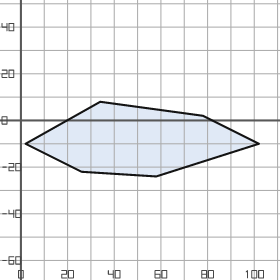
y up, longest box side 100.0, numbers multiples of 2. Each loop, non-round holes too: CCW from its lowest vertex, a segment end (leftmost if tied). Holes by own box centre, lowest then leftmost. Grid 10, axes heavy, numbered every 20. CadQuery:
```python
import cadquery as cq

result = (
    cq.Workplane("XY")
    .moveTo(58.0, -24.0)
    .lineTo(102.0, -10.0)
    .lineTo(78.0, 2.0)
    .lineTo(34.0, 8.0)
    .lineTo(2.0, -10.0)
    .lineTo(26.0, -22.0)
    .close()
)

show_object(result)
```